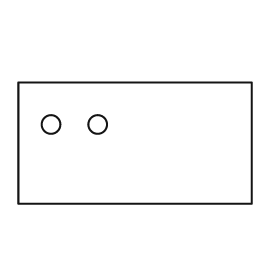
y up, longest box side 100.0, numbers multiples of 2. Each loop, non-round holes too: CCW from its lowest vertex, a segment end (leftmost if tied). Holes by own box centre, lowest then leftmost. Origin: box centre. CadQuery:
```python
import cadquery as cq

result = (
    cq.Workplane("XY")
    .moveTo(-50.0, -26.0)
    .lineTo(50.0, -26.0)
    .lineTo(50.0, 26.0)
    .lineTo(-50.0, 26.0)
    .close()
    .moveTo(-36.0, 8.0)
    .circle(4.0)
    .moveTo(-16.0, 8.0)
    .circle(4.0)
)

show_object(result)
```